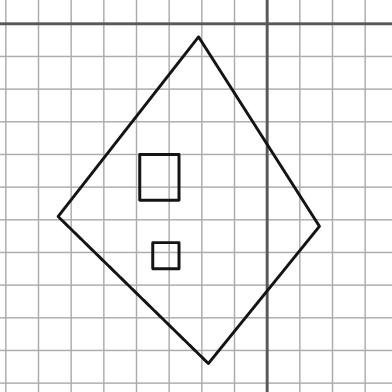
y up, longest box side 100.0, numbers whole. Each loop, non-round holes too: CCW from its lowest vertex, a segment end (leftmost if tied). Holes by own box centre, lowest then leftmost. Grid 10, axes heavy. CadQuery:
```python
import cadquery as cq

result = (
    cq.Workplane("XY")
    .moveTo(-18.0, -104.0)
    .lineTo(16.0, -62.0)
    .lineTo(-21.0, -4.0)
    .lineTo(-64.0, -59.0)
    .close()
    .moveTo(-35.0, -75.0)
    .lineTo(-27.0, -75.0)
    .lineTo(-27.0, -67.0)
    .lineTo(-35.0, -67.0)
    .close()
    .moveTo(-39.0, -54.0)
    .lineTo(-27.0, -54.0)
    .lineTo(-27.0, -40.0)
    .lineTo(-39.0, -40.0)
    .close()
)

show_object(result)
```